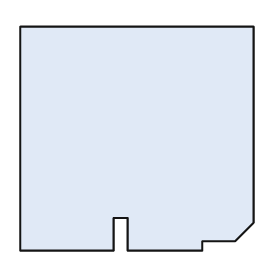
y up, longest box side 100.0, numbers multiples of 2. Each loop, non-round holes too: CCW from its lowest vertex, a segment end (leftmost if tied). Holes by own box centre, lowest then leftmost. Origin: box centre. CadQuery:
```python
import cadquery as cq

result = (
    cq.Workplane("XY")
    .moveTo(-50.0, -48.0)
    .lineTo(-10.0, -48.0)
    .lineTo(-10.0, -34.0)
    .lineTo(-4.0, -34.0)
    .lineTo(-4.0, -48.0)
    .lineTo(28.0, -48.0)
    .lineTo(28.0, -44.0)
    .lineTo(42.0, -44.0)
    .lineTo(50.0, -36.0)
    .lineTo(50.0, 48.0)
    .lineTo(-50.0, 48.0)
    .close()
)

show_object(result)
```